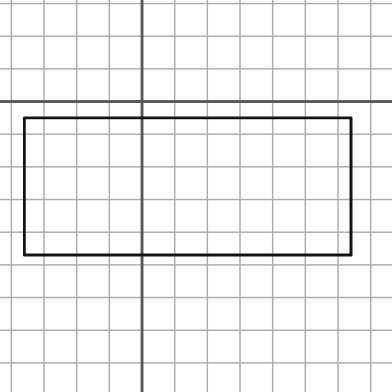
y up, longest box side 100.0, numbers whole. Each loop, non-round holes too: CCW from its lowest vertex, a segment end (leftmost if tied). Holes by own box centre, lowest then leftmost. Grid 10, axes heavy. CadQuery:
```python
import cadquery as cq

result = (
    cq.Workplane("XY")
    .moveTo(-36.0, -47.0)
    .lineTo(64.0, -47.0)
    .lineTo(64.0, -5.0)
    .lineTo(-36.0, -5.0)
    .close()
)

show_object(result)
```